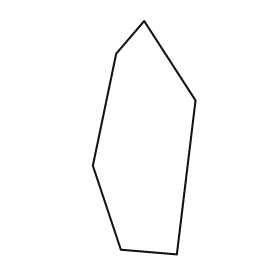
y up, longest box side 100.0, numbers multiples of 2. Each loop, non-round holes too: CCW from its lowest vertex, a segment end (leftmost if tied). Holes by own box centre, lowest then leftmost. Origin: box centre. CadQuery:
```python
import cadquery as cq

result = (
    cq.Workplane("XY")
    .moveTo(14.0, -50.0)
    .lineTo(22.0, 16.0)
    .lineTo(0.0, 50.0)
    .lineTo(-12.0, 36.0)
    .lineTo(-22.0, -12.0)
    .lineTo(-10.0, -48.0)
    .close()
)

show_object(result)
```